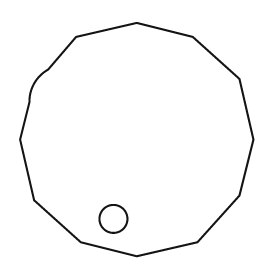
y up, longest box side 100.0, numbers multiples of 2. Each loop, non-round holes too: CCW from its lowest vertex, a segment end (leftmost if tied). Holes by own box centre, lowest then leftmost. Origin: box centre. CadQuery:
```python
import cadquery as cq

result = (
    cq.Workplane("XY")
    .moveTo(0.0, -50.0)
    .lineTo(26.0, -44.0)
    .lineTo(44.0, -24.0)
    .lineTo(50.0, 0.0)
    .lineTo(44.0, 26.0)
    .lineTo(24.0, 44.0)
    .lineTo(0.0, 50.0)
    .lineTo(-26.0, 44.0)
    .lineTo(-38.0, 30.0)
    .threePointArc((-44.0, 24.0), (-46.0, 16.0))
    .lineTo(-50.0, 0.0)
    .lineTo(-44.0, -26.0)
    .lineTo(-24.0, -44.0)
    .close()
    .moveTo(-10.0, -34.0)
    .circle(6.0)
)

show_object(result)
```